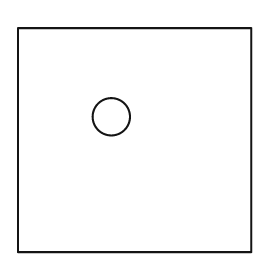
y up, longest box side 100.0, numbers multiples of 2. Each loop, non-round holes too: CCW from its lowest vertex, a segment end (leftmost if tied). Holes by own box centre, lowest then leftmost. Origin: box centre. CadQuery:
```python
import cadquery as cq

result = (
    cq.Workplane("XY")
    .moveTo(-50.0, -48.0)
    .lineTo(50.0, -48.0)
    .lineTo(50.0, 48.0)
    .lineTo(-50.0, 48.0)
    .close()
    .moveTo(-10.0, 10.0)
    .circle(8.0)
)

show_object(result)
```